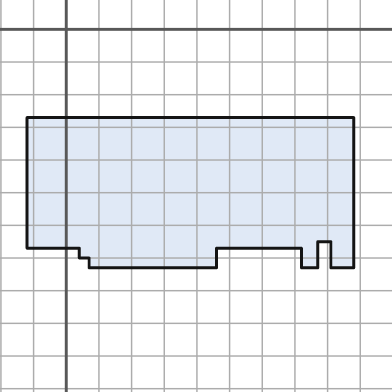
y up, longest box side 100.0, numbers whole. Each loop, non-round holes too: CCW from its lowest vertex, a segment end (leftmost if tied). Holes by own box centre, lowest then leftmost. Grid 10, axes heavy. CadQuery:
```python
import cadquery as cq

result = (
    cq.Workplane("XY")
    .moveTo(7.0, -73.0)
    .lineTo(46.0, -73.0)
    .lineTo(46.0, -67.0)
    .lineTo(72.0, -67.0)
    .lineTo(72.0, -73.0)
    .lineTo(77.0, -73.0)
    .lineTo(77.0, -65.0)
    .lineTo(81.0, -65.0)
    .lineTo(81.0, -73.0)
    .lineTo(88.0, -73.0)
    .lineTo(88.0, -27.0)
    .lineTo(-12.0, -27.0)
    .lineTo(-12.0, -67.0)
    .lineTo(4.0, -67.0)
    .lineTo(4.0, -70.0)
    .lineTo(7.0, -70.0)
    .close()
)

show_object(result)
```